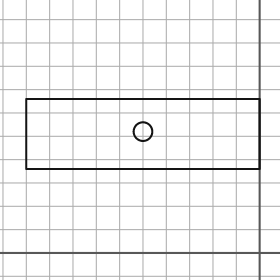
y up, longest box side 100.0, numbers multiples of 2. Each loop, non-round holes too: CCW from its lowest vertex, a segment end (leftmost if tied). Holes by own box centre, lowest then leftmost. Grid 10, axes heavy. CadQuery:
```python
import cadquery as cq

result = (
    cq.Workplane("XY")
    .moveTo(-100.0, 36.0)
    .lineTo(0.0, 36.0)
    .lineTo(0.0, 66.0)
    .lineTo(-100.0, 66.0)
    .close()
    .moveTo(-50.0, 52.0)
    .circle(4.0)
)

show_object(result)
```